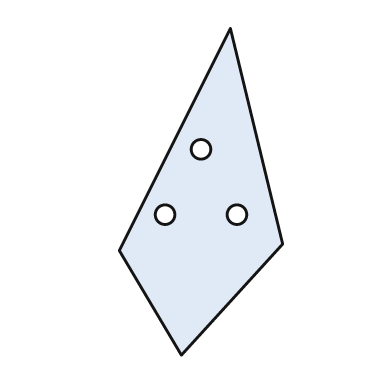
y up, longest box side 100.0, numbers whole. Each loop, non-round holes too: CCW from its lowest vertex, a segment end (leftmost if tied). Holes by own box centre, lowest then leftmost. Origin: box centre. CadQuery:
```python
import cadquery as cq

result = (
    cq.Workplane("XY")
    .moveTo(-6.0, -50.0)
    .lineTo(25.0, -16.0)
    .lineTo(9.0, 50.0)
    .lineTo(-25.0, -18.0)
    .close()
    .moveTo(-11.0, -7.0)
    .circle(3.0)
    .moveTo(11.0, -7.0)
    .circle(3.0)
    .moveTo(0.0, 13.0)
    .circle(3.0)
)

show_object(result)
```